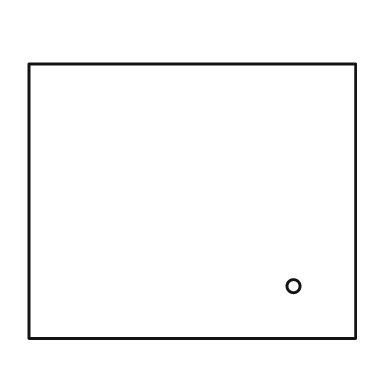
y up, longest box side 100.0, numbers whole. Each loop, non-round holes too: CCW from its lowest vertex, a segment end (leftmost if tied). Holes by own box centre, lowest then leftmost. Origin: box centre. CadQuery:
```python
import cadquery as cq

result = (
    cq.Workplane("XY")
    .moveTo(-50.0, -42.0)
    .lineTo(50.0, -42.0)
    .lineTo(50.0, 42.0)
    .lineTo(-50.0, 42.0)
    .close()
    .moveTo(31.0, -26.0)
    .circle(2.0)
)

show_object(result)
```